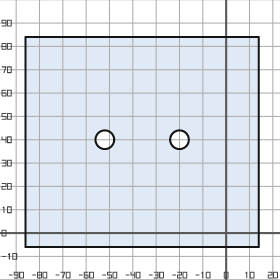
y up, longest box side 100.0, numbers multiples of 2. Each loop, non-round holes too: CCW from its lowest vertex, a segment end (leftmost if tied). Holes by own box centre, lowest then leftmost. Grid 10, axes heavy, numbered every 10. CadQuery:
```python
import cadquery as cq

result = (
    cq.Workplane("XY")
    .moveTo(-86.0, -6.0)
    .lineTo(14.0, -6.0)
    .lineTo(14.0, 84.0)
    .lineTo(-86.0, 84.0)
    .close()
    .moveTo(-52.0, 40.0)
    .circle(4.0)
    .moveTo(-20.0, 40.0)
    .circle(4.0)
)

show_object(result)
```